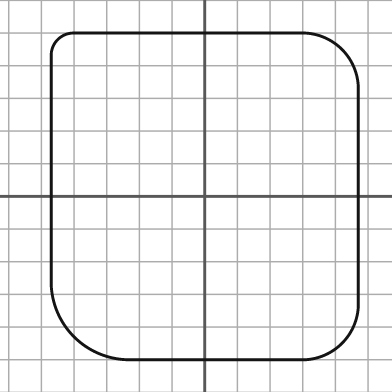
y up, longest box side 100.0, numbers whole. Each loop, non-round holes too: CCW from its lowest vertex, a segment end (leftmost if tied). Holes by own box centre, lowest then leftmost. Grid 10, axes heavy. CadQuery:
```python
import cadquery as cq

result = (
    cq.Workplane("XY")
    .moveTo(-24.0, -50.0)
    .lineTo(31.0, -50.0)
    .threePointArc((42.0, -45.0), (47.0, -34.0))
    .lineTo(47.0, 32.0)
    .threePointArc((42.0, 45.0), (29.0, 50.0))
    .lineTo(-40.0, 50.0)
    .threePointArc((-45.0, 48.0), (-47.0, 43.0))
    .lineTo(-47.0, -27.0)
    .threePointArc((-40.0, -43.0), (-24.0, -50.0))
    .close()
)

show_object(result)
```